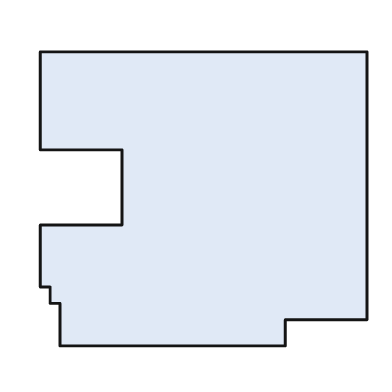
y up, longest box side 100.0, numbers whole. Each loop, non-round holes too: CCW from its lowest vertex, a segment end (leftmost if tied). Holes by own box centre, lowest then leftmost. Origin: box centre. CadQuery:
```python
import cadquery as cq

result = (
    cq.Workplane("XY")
    .moveTo(-44.0, -45.0)
    .lineTo(25.0, -45.0)
    .lineTo(25.0, -37.0)
    .lineTo(50.0, -37.0)
    .lineTo(50.0, 45.0)
    .lineTo(-50.0, 45.0)
    .lineTo(-50.0, 15.0)
    .lineTo(-25.0, 15.0)
    .lineTo(-25.0, -8.0)
    .lineTo(-50.0, -8.0)
    .lineTo(-50.0, -27.0)
    .lineTo(-47.0, -27.0)
    .lineTo(-47.0, -32.0)
    .lineTo(-44.0, -32.0)
    .close()
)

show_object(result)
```